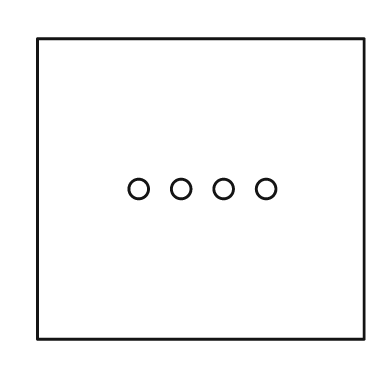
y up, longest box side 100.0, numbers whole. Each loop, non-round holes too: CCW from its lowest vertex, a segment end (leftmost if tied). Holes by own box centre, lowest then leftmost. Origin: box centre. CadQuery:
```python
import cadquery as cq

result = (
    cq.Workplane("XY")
    .moveTo(-50.0, -46.0)
    .lineTo(50.0, -46.0)
    .lineTo(50.0, 46.0)
    .lineTo(-50.0, 46.0)
    .close()
    .moveTo(-19.0, 0.0)
    .circle(3.0)
    .moveTo(-6.0, 0.0)
    .circle(3.0)
    .moveTo(7.0, 0.0)
    .circle(3.0)
    .moveTo(20.0, 0.0)
    .circle(3.0)
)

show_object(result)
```